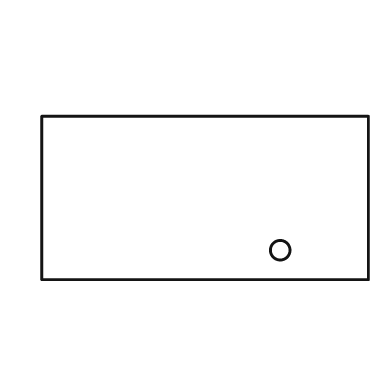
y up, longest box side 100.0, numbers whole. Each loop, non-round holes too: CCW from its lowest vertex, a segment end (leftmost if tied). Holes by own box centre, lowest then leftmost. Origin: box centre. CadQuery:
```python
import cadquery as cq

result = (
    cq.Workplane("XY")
    .moveTo(-50.0, -25.0)
    .lineTo(50.0, -25.0)
    .lineTo(50.0, 25.0)
    .lineTo(-50.0, 25.0)
    .close()
    .moveTo(23.0, -16.0)
    .circle(3.0)
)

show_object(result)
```